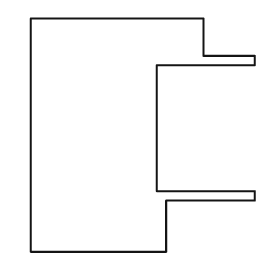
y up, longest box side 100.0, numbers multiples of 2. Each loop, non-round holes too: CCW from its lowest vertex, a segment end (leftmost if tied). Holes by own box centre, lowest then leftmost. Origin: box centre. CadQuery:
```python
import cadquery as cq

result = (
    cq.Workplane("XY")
    .moveTo(-48.0, -50.0)
    .lineTo(10.0, -50.0)
    .lineTo(10.0, -28.0)
    .lineTo(48.0, -28.0)
    .lineTo(48.0, -24.0)
    .lineTo(6.0, -24.0)
    .lineTo(6.0, 30.0)
    .lineTo(48.0, 30.0)
    .lineTo(48.0, 34.0)
    .lineTo(26.0, 34.0)
    .lineTo(26.0, 50.0)
    .lineTo(-48.0, 50.0)
    .close()
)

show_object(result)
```